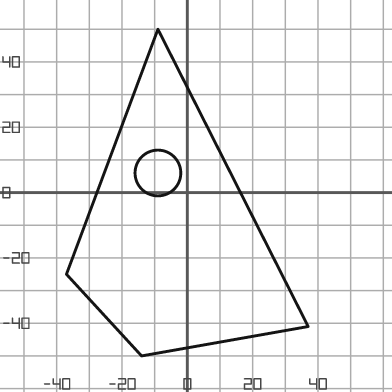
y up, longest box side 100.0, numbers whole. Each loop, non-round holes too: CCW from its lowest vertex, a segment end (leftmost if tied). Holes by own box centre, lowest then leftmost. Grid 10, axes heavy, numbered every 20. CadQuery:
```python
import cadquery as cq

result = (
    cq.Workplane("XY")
    .moveTo(-14.0, -50.0)
    .lineTo(37.0, -41.0)
    .lineTo(-9.0, 50.0)
    .lineTo(-37.0, -25.0)
    .close()
    .moveTo(-9.0, 6.0)
    .circle(7.0)
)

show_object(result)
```